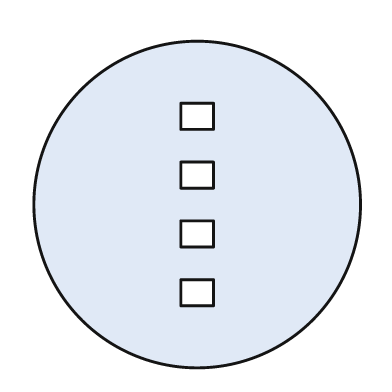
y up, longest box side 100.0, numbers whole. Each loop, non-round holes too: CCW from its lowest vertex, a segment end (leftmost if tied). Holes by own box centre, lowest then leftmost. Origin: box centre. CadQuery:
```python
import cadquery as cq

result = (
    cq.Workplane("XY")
    .moveTo(0.0, 0.0)
    .circle(50.0)
    .moveTo(-5.0, -31.0)
    .lineTo(5.0, -31.0)
    .lineTo(5.0, -23.0)
    .lineTo(-5.0, -23.0)
    .close()
    .moveTo(-5.0, -13.0)
    .lineTo(5.0, -13.0)
    .lineTo(5.0, -5.0)
    .lineTo(-5.0, -5.0)
    .close()
    .moveTo(-5.0, 5.0)
    .lineTo(5.0, 5.0)
    .lineTo(5.0, 13.0)
    .lineTo(-5.0, 13.0)
    .close()
    .moveTo(-5.0, 23.0)
    .lineTo(5.0, 23.0)
    .lineTo(5.0, 31.0)
    .lineTo(-5.0, 31.0)
    .close()
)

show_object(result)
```